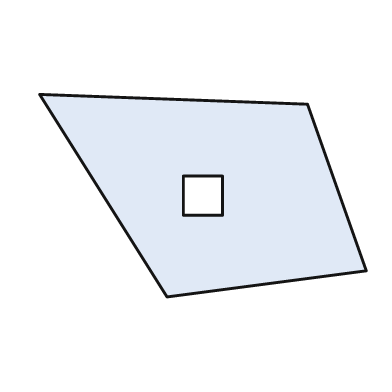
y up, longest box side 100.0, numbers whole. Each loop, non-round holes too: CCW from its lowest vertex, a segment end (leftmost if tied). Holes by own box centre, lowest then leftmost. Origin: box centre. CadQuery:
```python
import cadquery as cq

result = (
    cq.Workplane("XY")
    .moveTo(-11.0, -31.0)
    .lineTo(50.0, -23.0)
    .lineTo(32.0, 28.0)
    .lineTo(-50.0, 31.0)
    .close()
    .moveTo(-6.0, -6.0)
    .lineTo(6.0, -6.0)
    .lineTo(6.0, 6.0)
    .lineTo(-6.0, 6.0)
    .close()
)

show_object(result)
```